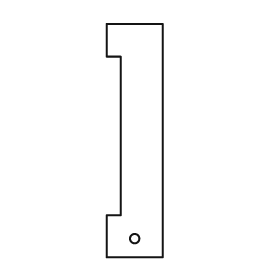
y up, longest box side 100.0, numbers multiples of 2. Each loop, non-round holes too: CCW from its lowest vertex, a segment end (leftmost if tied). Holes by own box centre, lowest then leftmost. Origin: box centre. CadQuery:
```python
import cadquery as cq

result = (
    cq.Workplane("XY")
    .moveTo(-12.0, -50.0)
    .lineTo(12.0, -50.0)
    .lineTo(12.0, 50.0)
    .lineTo(-12.0, 50.0)
    .lineTo(-12.0, 36.0)
    .lineTo(-6.0, 36.0)
    .lineTo(-6.0, -32.0)
    .lineTo(-12.0, -32.0)
    .close()
    .moveTo(0.0, -42.0)
    .circle(2.0)
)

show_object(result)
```